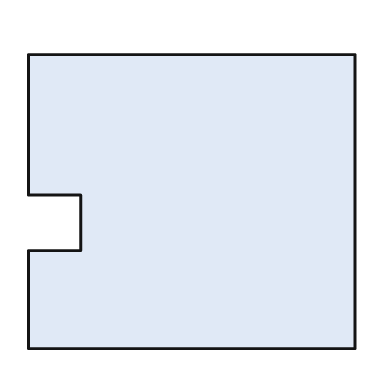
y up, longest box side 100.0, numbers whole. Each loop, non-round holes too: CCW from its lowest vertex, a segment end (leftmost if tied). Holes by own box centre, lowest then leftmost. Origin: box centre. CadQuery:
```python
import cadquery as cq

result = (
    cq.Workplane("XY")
    .moveTo(-50.0, -45.0)
    .lineTo(50.0, -45.0)
    .lineTo(50.0, 45.0)
    .lineTo(-50.0, 45.0)
    .lineTo(-50.0, 2.0)
    .lineTo(-34.0, 2.0)
    .lineTo(-34.0, -15.0)
    .lineTo(-50.0, -15.0)
    .close()
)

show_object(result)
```